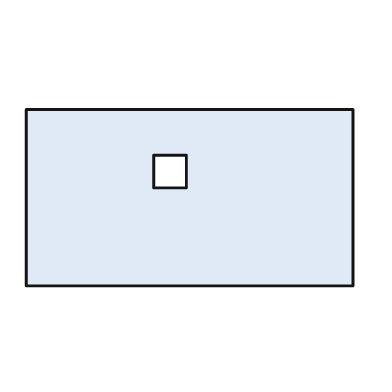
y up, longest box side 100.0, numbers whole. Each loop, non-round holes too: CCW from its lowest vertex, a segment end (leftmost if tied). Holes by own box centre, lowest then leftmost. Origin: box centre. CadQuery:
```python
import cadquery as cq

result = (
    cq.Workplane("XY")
    .moveTo(-50.0, -27.0)
    .lineTo(50.0, -27.0)
    .lineTo(50.0, 27.0)
    .lineTo(-50.0, 27.0)
    .close()
    .moveTo(-11.0, 3.0)
    .lineTo(-1.0, 3.0)
    .lineTo(-1.0, 13.0)
    .lineTo(-11.0, 13.0)
    .close()
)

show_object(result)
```